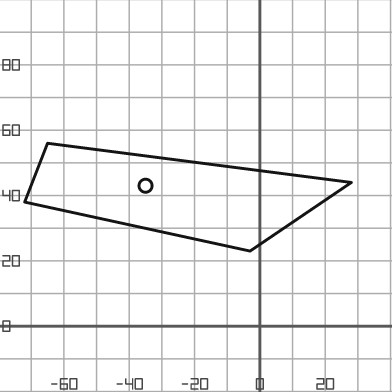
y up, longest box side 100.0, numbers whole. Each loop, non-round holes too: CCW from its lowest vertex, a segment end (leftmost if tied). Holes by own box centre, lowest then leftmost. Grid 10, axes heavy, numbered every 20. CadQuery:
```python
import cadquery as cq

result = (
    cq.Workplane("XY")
    .moveTo(-3.0, 23.0)
    .lineTo(28.0, 44.0)
    .lineTo(-65.0, 56.0)
    .lineTo(-72.0, 38.0)
    .close()
    .moveTo(-35.0, 43.0)
    .circle(2.0)
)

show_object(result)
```